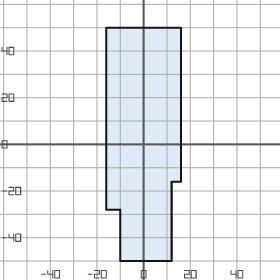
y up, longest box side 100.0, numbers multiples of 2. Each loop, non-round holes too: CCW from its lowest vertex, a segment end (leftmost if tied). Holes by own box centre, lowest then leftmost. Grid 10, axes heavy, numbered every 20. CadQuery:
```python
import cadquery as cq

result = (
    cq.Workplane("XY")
    .moveTo(-10.0, -50.0)
    .lineTo(12.0, -50.0)
    .lineTo(12.0, -16.0)
    .lineTo(16.0, -16.0)
    .lineTo(16.0, 50.0)
    .lineTo(-16.0, 50.0)
    .lineTo(-16.0, -28.0)
    .lineTo(-10.0, -28.0)
    .close()
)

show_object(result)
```